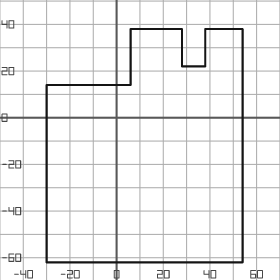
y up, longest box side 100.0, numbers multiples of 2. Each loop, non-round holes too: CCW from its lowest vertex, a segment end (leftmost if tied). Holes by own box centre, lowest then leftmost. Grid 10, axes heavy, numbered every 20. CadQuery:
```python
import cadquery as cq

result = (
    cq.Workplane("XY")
    .moveTo(-30.0, -62.0)
    .lineTo(54.0, -62.0)
    .lineTo(54.0, 38.0)
    .lineTo(38.0, 38.0)
    .lineTo(38.0, 22.0)
    .lineTo(28.0, 22.0)
    .lineTo(28.0, 38.0)
    .lineTo(6.0, 38.0)
    .lineTo(6.0, 14.0)
    .lineTo(-30.0, 14.0)
    .close()
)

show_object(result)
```